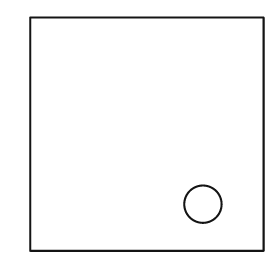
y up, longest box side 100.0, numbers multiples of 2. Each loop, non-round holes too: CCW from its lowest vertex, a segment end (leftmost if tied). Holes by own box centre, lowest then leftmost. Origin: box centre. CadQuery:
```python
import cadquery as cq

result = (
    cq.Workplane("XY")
    .moveTo(-50.0, -50.0)
    .lineTo(50.0, -50.0)
    .lineTo(50.0, 50.0)
    .lineTo(-50.0, 50.0)
    .close()
    .moveTo(24.0, -30.0)
    .circle(8.0)
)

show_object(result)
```